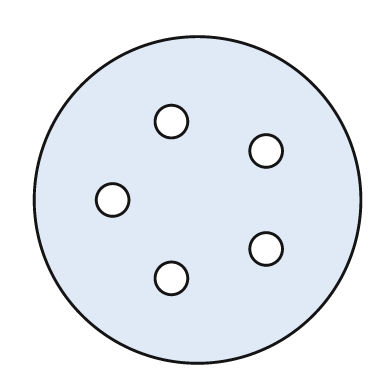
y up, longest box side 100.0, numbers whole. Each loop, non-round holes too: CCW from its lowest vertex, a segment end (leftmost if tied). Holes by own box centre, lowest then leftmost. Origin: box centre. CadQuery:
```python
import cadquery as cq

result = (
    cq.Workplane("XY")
    .moveTo(0.0, 0.0)
    .circle(50.0)
    .moveTo(-8.0, -24.0)
    .circle(5.0)
    .moveTo(21.0, -15.0)
    .circle(5.0)
    .moveTo(-26.0, 0.0)
    .circle(5.0)
    .moveTo(21.0, 15.0)
    .circle(5.0)
    .moveTo(-8.0, 24.0)
    .circle(5.0)
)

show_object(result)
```